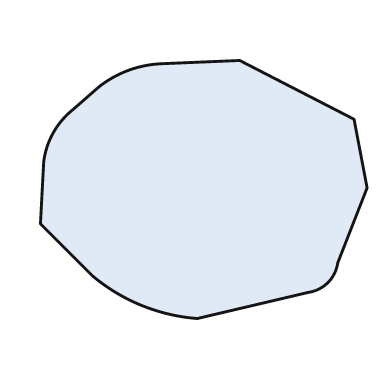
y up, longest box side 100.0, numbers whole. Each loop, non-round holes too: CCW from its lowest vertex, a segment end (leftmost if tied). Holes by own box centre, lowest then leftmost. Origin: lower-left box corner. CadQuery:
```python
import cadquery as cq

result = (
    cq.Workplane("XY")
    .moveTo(48.0, 0.0)
    .lineTo(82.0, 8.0)
    .threePointArc((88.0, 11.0), (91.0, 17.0))
    .lineTo(100.0, 40.0)
    .lineTo(96.0, 61.0)
    .lineTo(61.0, 79.0)
    .lineTo(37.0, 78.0)
    .threePointArc((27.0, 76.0), (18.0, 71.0))
    .lineTo(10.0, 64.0)
    .threePointArc((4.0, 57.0), (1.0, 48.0))
    .lineTo(0.0, 29.0)
    .lineTo(16.0, 13.0)
    .threePointArc((31.0, 4.0), (48.0, 0.0))
    .close()
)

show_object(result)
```